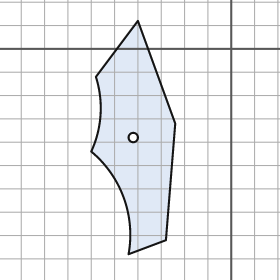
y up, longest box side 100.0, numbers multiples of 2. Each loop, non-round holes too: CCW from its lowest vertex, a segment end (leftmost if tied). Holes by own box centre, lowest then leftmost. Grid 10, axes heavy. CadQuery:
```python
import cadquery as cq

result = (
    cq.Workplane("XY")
    .moveTo(-44.0, -88.0)
    .lineTo(-28.0, -82.0)
    .lineTo(-24.0, -32.0)
    .lineTo(-40.0, 12.0)
    .lineTo(-58.0, -12.0)
    .threePointArc((-56.0, -28.0), (-60.0, -44.0))
    .threePointArc((-46.0, -64.0), (-44.0, -88.0))
    .close()
    .moveTo(-42.0, -38.0)
    .circle(2.0)
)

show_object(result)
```